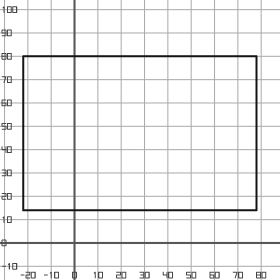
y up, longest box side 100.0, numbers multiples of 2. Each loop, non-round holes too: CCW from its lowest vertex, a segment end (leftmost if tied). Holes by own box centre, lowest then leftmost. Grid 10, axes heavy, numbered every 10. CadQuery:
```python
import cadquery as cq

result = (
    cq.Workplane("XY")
    .moveTo(-22.0, 14.0)
    .lineTo(78.0, 14.0)
    .lineTo(78.0, 80.0)
    .lineTo(-22.0, 80.0)
    .close()
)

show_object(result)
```